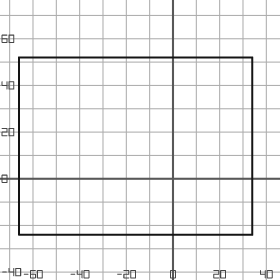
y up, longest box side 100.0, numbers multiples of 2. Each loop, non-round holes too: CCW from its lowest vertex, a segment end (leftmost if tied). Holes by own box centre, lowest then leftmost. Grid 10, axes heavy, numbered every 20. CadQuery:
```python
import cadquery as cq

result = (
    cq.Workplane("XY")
    .moveTo(-66.0, -24.0)
    .lineTo(34.0, -24.0)
    .lineTo(34.0, 52.0)
    .lineTo(-66.0, 52.0)
    .close()
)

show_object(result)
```